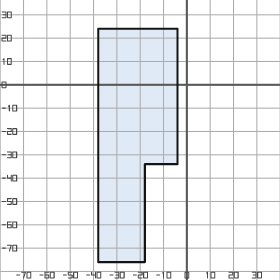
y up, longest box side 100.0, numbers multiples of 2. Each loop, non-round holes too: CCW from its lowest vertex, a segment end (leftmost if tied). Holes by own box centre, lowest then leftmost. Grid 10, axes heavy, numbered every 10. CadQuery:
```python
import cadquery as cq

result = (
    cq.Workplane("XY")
    .moveTo(-38.0, -76.0)
    .lineTo(-18.0, -76.0)
    .lineTo(-18.0, -34.0)
    .lineTo(-4.0, -34.0)
    .lineTo(-4.0, 24.0)
    .lineTo(-38.0, 24.0)
    .close()
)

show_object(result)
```